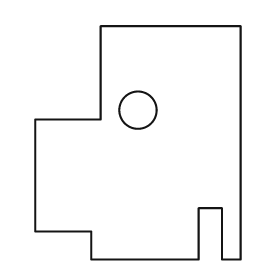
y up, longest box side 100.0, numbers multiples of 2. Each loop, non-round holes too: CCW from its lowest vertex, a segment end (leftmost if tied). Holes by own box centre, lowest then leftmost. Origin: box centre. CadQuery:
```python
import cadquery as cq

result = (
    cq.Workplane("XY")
    .moveTo(-20.0, -50.0)
    .lineTo(26.0, -50.0)
    .lineTo(26.0, -28.0)
    .lineTo(36.0, -28.0)
    .lineTo(36.0, -50.0)
    .lineTo(44.0, -50.0)
    .lineTo(44.0, 50.0)
    .lineTo(-16.0, 50.0)
    .lineTo(-16.0, 10.0)
    .lineTo(-44.0, 10.0)
    .lineTo(-44.0, -38.0)
    .lineTo(-20.0, -38.0)
    .close()
    .moveTo(0.0, 14.0)
    .circle(8.0)
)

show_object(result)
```